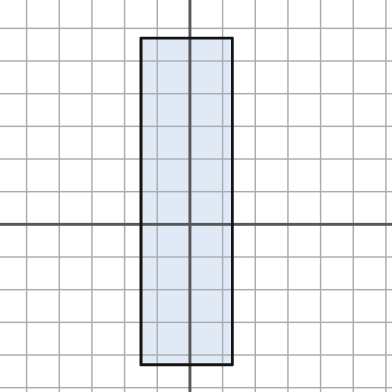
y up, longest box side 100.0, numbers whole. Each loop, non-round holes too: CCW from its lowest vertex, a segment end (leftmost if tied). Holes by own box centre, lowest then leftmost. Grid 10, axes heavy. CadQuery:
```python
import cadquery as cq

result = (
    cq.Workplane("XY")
    .moveTo(-15.0, -43.0)
    .lineTo(13.0, -43.0)
    .lineTo(13.0, 57.0)
    .lineTo(-15.0, 57.0)
    .close()
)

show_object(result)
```